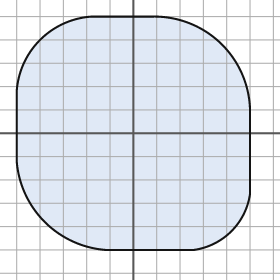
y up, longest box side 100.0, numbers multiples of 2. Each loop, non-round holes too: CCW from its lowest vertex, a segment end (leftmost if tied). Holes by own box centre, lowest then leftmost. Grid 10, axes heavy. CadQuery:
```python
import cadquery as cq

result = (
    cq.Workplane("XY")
    .moveTo(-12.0, -50.0)
    .lineTo(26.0, -50.0)
    .threePointArc((42.0, -42.0), (50.0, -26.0))
    .lineTo(50.0, 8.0)
    .threePointArc((38.0, 38.0), (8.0, 50.0))
    .lineTo(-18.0, 50.0)
    .threePointArc((-40.0, 40.0), (-50.0, 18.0))
    .lineTo(-50.0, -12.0)
    .threePointArc((-38.0, -38.0), (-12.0, -50.0))
    .close()
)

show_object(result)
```